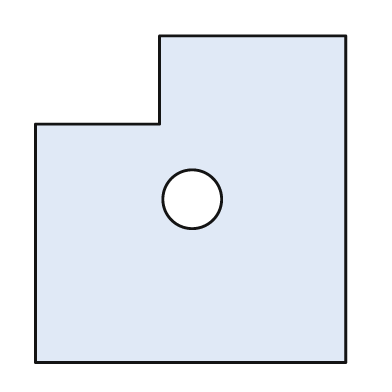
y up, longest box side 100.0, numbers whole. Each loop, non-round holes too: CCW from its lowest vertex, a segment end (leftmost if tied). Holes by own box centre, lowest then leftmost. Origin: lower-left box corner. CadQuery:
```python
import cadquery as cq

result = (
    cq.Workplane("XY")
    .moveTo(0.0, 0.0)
    .lineTo(95.0, 0.0)
    .lineTo(95.0, 100.0)
    .lineTo(38.0, 100.0)
    .lineTo(38.0, 73.0)
    .lineTo(0.0, 73.0)
    .close()
    .moveTo(48.0, 50.0)
    .circle(9.0)
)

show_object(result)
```